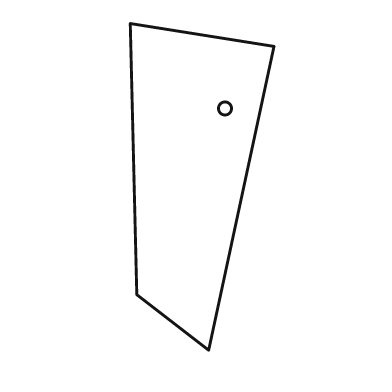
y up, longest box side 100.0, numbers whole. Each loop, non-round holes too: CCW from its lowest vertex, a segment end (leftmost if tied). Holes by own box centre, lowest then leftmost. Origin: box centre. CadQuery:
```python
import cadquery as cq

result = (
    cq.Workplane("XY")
    .moveTo(2.0, -50.0)
    .lineTo(22.0, 43.0)
    .lineTo(-22.0, 50.0)
    .lineTo(-20.0, -33.0)
    .close()
    .moveTo(7.0, 24.0)
    .circle(2.0)
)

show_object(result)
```